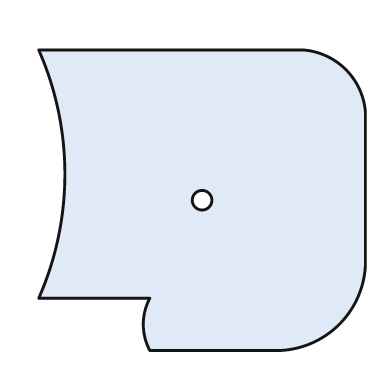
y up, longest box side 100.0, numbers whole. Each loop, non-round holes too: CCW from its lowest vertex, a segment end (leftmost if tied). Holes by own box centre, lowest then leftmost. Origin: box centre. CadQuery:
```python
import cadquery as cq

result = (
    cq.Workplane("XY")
    .moveTo(-16.0, -46.0)
    .lineTo(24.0, -46.0)
    .threePointArc((42.0, -38.0), (50.0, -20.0))
    .lineTo(50.0, 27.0)
    .threePointArc((44.0, 40.0), (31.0, 46.0))
    .lineTo(-50.0, 46.0)
    .threePointArc((-42.0, 8.0), (-50.0, -30.0))
    .lineTo(-16.0, -30.0)
    .threePointArc((-18.0, -38.0), (-16.0, -46.0))
    .close()
    .moveTo(0.0, 0.0)
    .circle(3.0)
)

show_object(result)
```